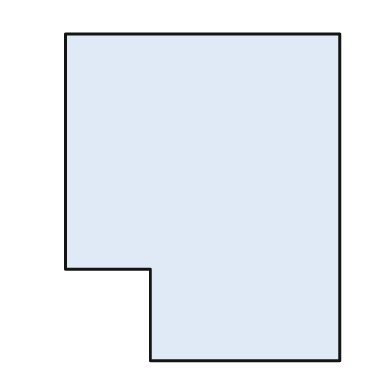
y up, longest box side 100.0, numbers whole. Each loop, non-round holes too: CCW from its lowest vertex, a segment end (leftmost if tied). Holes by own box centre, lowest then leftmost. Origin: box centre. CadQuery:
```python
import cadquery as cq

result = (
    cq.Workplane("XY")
    .moveTo(-16.0, -50.0)
    .lineTo(42.0, -50.0)
    .lineTo(42.0, 50.0)
    .lineTo(-42.0, 50.0)
    .lineTo(-42.0, -22.0)
    .lineTo(-16.0, -22.0)
    .close()
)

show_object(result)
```